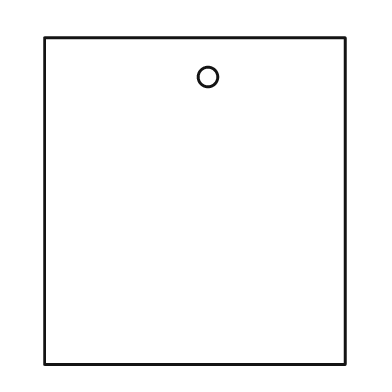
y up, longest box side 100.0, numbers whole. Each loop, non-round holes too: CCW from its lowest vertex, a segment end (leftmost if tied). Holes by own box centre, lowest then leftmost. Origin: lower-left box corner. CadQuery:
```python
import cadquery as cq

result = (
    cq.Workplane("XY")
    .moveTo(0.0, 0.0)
    .lineTo(92.0, 0.0)
    .lineTo(92.0, 100.0)
    .lineTo(0.0, 100.0)
    .close()
    .moveTo(50.0, 88.0)
    .circle(3.0)
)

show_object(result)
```